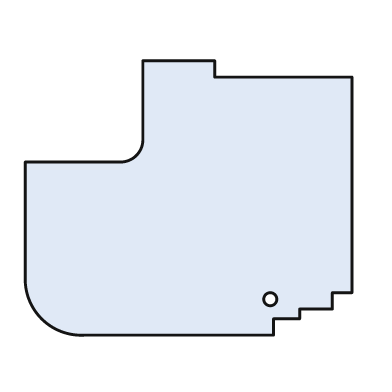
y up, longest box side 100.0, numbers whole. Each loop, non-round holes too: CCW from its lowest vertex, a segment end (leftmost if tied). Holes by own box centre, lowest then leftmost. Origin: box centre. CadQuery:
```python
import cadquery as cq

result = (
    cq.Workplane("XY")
    .moveTo(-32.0, -42.0)
    .lineTo(26.0, -42.0)
    .lineTo(26.0, -37.0)
    .lineTo(34.0, -37.0)
    .lineTo(34.0, -34.0)
    .lineTo(44.0, -34.0)
    .lineTo(44.0, -29.0)
    .lineTo(50.0, -29.0)
    .lineTo(50.0, 37.0)
    .lineTo(8.0, 37.0)
    .lineTo(8.0, 42.0)
    .lineTo(-14.0, 42.0)
    .lineTo(-14.0, 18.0)
    .threePointArc((-16.0, 13.0), (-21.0, 11.0))
    .lineTo(-50.0, 11.0)
    .lineTo(-50.0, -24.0)
    .threePointArc((-45.0, -37.0), (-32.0, -42.0))
    .close()
    .moveTo(25.0, -31.0)
    .circle(2.0)
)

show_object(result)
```